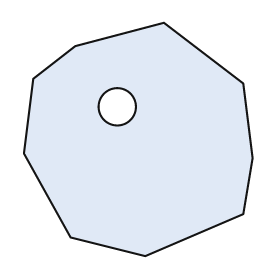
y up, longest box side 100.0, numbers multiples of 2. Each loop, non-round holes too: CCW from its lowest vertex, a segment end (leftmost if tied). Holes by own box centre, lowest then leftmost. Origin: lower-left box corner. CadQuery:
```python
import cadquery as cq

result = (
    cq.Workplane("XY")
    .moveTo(52.0, 0.0)
    .lineTo(94.0, 18.0)
    .lineTo(98.0, 42.0)
    .lineTo(94.0, 74.0)
    .lineTo(60.0, 100.0)
    .lineTo(22.0, 90.0)
    .lineTo(4.0, 76.0)
    .lineTo(0.0, 44.0)
    .lineTo(20.0, 8.0)
    .close()
    .moveTo(40.0, 64.0)
    .circle(8.0)
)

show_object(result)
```